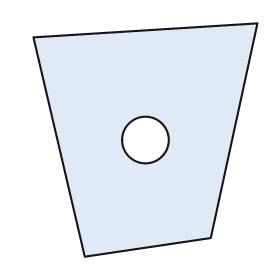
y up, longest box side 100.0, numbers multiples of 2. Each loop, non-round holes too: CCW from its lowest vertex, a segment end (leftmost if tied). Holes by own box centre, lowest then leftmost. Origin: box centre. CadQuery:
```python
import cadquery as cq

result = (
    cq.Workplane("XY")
    .moveTo(-26.0, -50.0)
    .lineTo(28.0, -42.0)
    .lineTo(48.0, 50.0)
    .lineTo(-48.0, 44.0)
    .close()
    .moveTo(0.0, 0.0)
    .circle(10.0)
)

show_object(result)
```